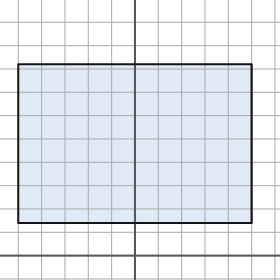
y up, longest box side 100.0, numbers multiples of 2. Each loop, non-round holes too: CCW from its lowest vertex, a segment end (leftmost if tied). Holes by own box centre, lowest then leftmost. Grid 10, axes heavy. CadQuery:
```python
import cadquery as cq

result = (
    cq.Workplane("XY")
    .moveTo(-50.0, 14.0)
    .lineTo(50.0, 14.0)
    .lineTo(50.0, 82.0)
    .lineTo(-50.0, 82.0)
    .close()
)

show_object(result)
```